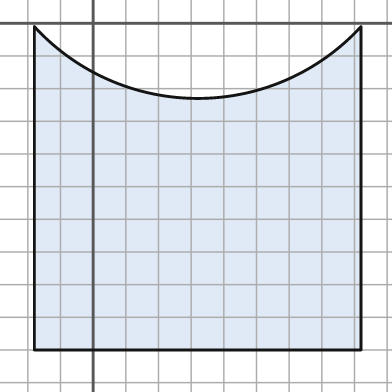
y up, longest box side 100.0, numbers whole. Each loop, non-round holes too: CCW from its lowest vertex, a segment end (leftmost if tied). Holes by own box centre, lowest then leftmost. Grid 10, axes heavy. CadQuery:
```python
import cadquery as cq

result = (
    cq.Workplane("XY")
    .moveTo(-18.0, -100.0)
    .lineTo(82.0, -100.0)
    .lineTo(82.0, -1.0)
    .threePointArc((32.0, -23.0), (-18.0, -1.0))
    .close()
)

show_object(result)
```